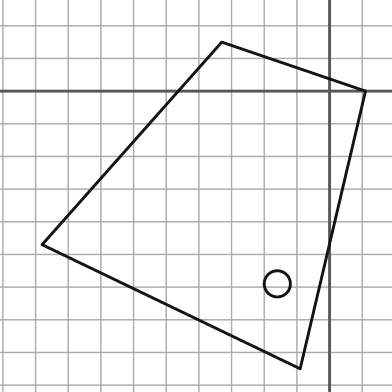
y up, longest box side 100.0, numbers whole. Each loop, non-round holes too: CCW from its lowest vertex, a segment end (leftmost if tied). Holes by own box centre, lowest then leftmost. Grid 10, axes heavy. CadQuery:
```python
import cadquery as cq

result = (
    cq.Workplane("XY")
    .moveTo(-9.0, -85.0)
    .lineTo(11.0, 0.0)
    .lineTo(-33.0, 15.0)
    .lineTo(-88.0, -47.0)
    .close()
    .moveTo(-16.0, -59.0)
    .circle(4.0)
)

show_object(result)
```